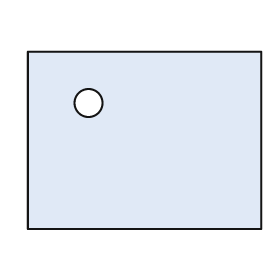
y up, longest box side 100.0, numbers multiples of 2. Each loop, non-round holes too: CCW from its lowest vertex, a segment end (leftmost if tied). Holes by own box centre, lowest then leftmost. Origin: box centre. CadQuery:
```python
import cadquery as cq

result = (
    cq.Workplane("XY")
    .moveTo(-50.0, -38.0)
    .lineTo(50.0, -38.0)
    .lineTo(50.0, 38.0)
    .lineTo(-50.0, 38.0)
    .close()
    .moveTo(-24.0, 16.0)
    .circle(6.0)
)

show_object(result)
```